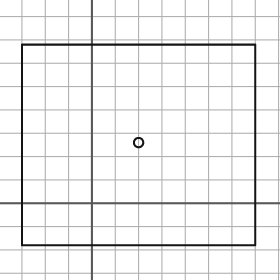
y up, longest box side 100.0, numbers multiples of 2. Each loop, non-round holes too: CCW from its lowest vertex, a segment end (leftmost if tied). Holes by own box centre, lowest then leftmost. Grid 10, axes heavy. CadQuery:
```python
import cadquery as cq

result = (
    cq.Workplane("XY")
    .moveTo(-30.0, -18.0)
    .lineTo(70.0, -18.0)
    .lineTo(70.0, 68.0)
    .lineTo(-30.0, 68.0)
    .close()
    .moveTo(20.0, 26.0)
    .circle(2.0)
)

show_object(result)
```